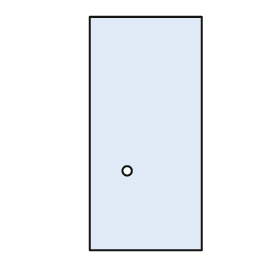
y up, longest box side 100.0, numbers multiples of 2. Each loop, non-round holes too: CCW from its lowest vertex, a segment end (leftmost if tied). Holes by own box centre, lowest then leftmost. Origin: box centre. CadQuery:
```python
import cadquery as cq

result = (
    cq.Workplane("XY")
    .moveTo(-24.0, -50.0)
    .lineTo(24.0, -50.0)
    .lineTo(24.0, 50.0)
    .lineTo(-24.0, 50.0)
    .close()
    .moveTo(-8.0, -16.0)
    .circle(2.0)
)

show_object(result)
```